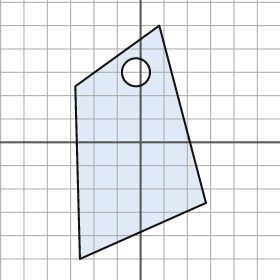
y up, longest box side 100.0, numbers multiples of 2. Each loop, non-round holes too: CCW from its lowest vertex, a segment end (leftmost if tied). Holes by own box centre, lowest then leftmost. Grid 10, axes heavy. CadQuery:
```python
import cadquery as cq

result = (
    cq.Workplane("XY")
    .moveTo(-26.0, -50.0)
    .lineTo(28.0, -26.0)
    .lineTo(8.0, 50.0)
    .lineTo(-28.0, 24.0)
    .close()
    .moveTo(-2.0, 30.0)
    .circle(6.0)
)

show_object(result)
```